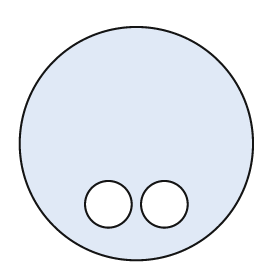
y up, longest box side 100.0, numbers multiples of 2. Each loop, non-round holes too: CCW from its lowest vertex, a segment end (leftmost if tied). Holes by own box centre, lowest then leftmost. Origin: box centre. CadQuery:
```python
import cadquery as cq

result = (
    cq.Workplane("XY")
    .moveTo(0.0, 0.0)
    .circle(50.0)
    .moveTo(-12.0, -26.0)
    .circle(10.0)
    .moveTo(12.0, -26.0)
    .circle(10.0)
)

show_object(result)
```